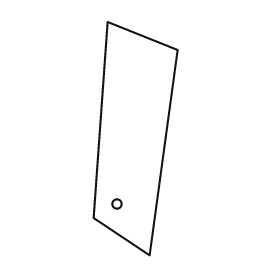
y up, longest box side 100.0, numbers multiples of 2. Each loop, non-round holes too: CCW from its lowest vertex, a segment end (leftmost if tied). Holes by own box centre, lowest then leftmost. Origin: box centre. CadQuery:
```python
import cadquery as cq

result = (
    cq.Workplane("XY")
    .moveTo(6.0, -50.0)
    .lineTo(18.0, 38.0)
    .lineTo(-12.0, 50.0)
    .lineTo(-18.0, -34.0)
    .close()
    .moveTo(-8.0, -28.0)
    .circle(2.0)
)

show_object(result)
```